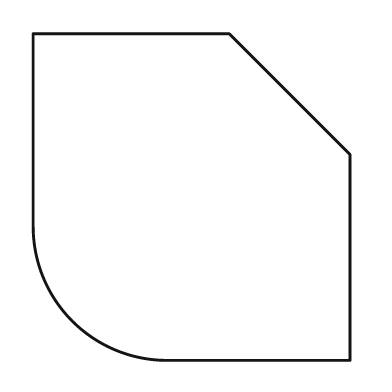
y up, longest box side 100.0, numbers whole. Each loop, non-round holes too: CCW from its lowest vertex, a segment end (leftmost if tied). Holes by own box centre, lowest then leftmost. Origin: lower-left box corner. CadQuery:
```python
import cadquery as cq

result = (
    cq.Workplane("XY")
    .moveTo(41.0, 0.0)
    .lineTo(97.0, 0.0)
    .lineTo(97.0, 63.0)
    .lineTo(60.0, 100.0)
    .lineTo(0.0, 100.0)
    .lineTo(0.0, 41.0)
    .threePointArc((12.0, 12.0), (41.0, 0.0))
    .close()
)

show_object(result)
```